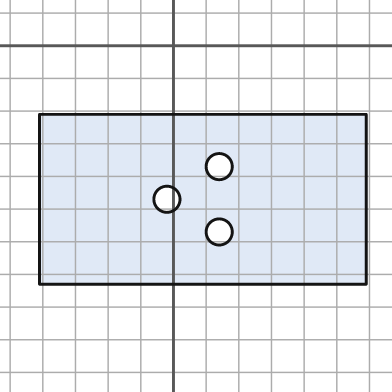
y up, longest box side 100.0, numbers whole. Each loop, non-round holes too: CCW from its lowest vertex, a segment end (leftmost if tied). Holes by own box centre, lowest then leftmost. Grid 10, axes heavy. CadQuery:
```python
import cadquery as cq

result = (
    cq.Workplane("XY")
    .moveTo(-41.0, -73.0)
    .lineTo(59.0, -73.0)
    .lineTo(59.0, -21.0)
    .lineTo(-41.0, -21.0)
    .close()
    .moveTo(14.0, -57.0)
    .circle(4.0)
    .moveTo(-2.0, -47.0)
    .circle(4.0)
    .moveTo(14.0, -37.0)
    .circle(4.0)
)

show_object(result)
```